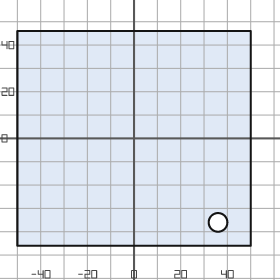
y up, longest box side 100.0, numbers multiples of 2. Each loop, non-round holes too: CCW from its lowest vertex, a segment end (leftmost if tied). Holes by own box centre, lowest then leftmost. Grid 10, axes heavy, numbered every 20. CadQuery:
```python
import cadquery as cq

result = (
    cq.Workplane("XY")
    .moveTo(-50.0, -46.0)
    .lineTo(50.0, -46.0)
    .lineTo(50.0, 46.0)
    .lineTo(-50.0, 46.0)
    .close()
    .moveTo(36.0, -36.0)
    .circle(4.0)
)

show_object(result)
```